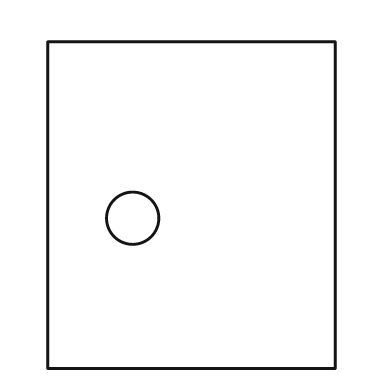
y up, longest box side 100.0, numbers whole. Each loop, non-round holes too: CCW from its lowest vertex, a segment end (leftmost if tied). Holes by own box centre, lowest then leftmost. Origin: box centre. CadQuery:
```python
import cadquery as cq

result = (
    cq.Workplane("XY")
    .moveTo(-44.0, -50.0)
    .lineTo(44.0, -50.0)
    .lineTo(44.0, 50.0)
    .lineTo(-44.0, 50.0)
    .close()
    .moveTo(-18.0, -4.0)
    .circle(8.0)
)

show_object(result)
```